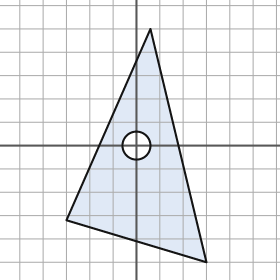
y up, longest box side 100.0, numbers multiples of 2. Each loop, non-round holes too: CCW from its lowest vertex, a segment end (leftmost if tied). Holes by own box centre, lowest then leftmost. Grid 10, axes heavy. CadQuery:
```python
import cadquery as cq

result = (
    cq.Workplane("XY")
    .moveTo(30.0, -50.0)
    .lineTo(6.0, 50.0)
    .lineTo(-30.0, -32.0)
    .close()
    .moveTo(0.0, 0.0)
    .circle(6.0)
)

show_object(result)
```